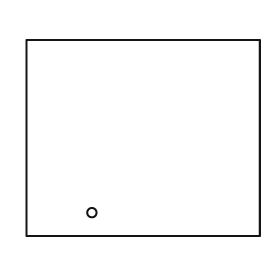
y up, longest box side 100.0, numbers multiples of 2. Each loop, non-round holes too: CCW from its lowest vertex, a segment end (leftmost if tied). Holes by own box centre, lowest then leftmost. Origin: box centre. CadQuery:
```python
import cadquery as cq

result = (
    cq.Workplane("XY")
    .moveTo(-50.0, -42.0)
    .lineTo(50.0, -42.0)
    .lineTo(50.0, 42.0)
    .lineTo(-50.0, 42.0)
    .close()
    .moveTo(-22.0, -32.0)
    .circle(2.0)
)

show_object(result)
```